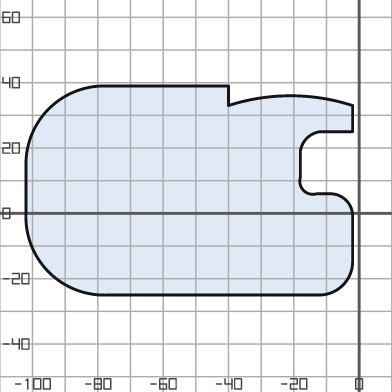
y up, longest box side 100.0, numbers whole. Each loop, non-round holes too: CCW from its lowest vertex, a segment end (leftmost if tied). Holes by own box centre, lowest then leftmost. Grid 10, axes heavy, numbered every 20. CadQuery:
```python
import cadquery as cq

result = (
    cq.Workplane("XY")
    .moveTo(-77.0, -25.0)
    .lineTo(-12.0, -25.0)
    .threePointArc((-5.0, -22.0), (-2.0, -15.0))
    .lineTo(-2.0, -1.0)
    .threePointArc((-4.0, 4.0), (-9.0, 6.0))
    .lineTo(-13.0, 6.0)
    .threePointArc((-17.0, 7.0), (-18.0, 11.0))
    .lineTo(-18.0, 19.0)
    .threePointArc((-16.0, 23.0), (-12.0, 25.0))
    .lineTo(-2.0, 25.0)
    .lineTo(-2.0, 33.0)
    .threePointArc((-21.0, 36.0), (-40.0, 33.0))
    .lineTo(-40.0, 39.0)
    .lineTo(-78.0, 39.0)
    .threePointArc((-95.0, 32.0), (-102.0, 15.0))
    .lineTo(-102.0, 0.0)
    .threePointArc((-95.0, -18.0), (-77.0, -25.0))
    .close()
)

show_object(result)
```